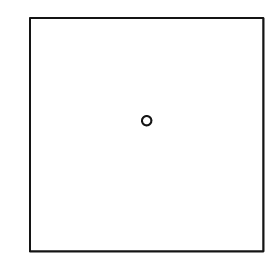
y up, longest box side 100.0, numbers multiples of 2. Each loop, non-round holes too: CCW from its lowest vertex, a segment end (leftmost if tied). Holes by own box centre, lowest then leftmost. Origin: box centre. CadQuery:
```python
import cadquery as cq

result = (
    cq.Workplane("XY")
    .moveTo(-50.0, -50.0)
    .lineTo(50.0, -50.0)
    .lineTo(50.0, 50.0)
    .lineTo(-50.0, 50.0)
    .close()
    .moveTo(0.0, 6.0)
    .circle(2.0)
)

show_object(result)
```